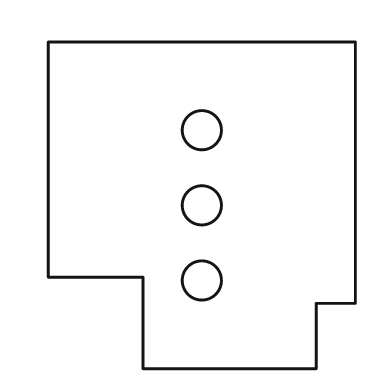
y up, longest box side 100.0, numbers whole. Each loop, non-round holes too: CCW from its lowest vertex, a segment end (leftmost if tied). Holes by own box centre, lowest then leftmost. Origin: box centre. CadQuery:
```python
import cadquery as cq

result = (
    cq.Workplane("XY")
    .moveTo(-18.0, -50.0)
    .lineTo(35.0, -50.0)
    .lineTo(35.0, -30.0)
    .lineTo(47.0, -30.0)
    .lineTo(47.0, 50.0)
    .lineTo(-47.0, 50.0)
    .lineTo(-47.0, -22.0)
    .lineTo(-18.0, -22.0)
    .close()
    .moveTo(0.0, -23.0)
    .circle(6.0)
    .moveTo(0.0, 0.0)
    .circle(6.0)
    .moveTo(0.0, 23.0)
    .circle(6.0)
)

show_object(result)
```